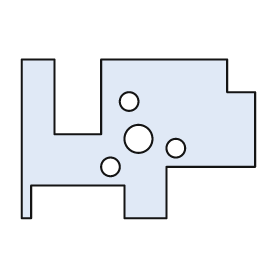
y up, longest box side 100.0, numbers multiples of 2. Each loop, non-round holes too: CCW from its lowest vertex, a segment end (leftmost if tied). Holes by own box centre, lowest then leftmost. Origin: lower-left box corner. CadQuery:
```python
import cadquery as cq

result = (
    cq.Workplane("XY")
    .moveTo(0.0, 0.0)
    .lineTo(4.0, 0.0)
    .lineTo(4.0, 14.0)
    .lineTo(44.0, 14.0)
    .lineTo(44.0, 0.0)
    .lineTo(62.0, 0.0)
    .lineTo(62.0, 22.0)
    .lineTo(100.0, 22.0)
    .lineTo(100.0, 54.0)
    .lineTo(88.0, 54.0)
    .lineTo(88.0, 68.0)
    .lineTo(34.0, 68.0)
    .lineTo(34.0, 36.0)
    .lineTo(14.0, 36.0)
    .lineTo(14.0, 68.0)
    .lineTo(0.0, 68.0)
    .close()
    .moveTo(38.0, 22.0)
    .circle(4.0)
    .moveTo(66.0, 30.0)
    .circle(4.0)
    .moveTo(50.0, 34.0)
    .circle(6.0)
    .moveTo(46.0, 50.0)
    .circle(4.0)
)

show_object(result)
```